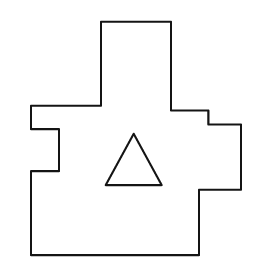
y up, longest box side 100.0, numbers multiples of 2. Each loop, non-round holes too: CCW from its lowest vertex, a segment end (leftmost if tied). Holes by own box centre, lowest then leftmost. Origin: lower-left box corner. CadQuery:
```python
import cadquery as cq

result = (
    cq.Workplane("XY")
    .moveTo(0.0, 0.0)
    .lineTo(72.0, 0.0)
    .lineTo(72.0, 28.0)
    .lineTo(90.0, 28.0)
    .lineTo(90.0, 56.0)
    .lineTo(76.0, 56.0)
    .lineTo(76.0, 62.0)
    .lineTo(60.0, 62.0)
    .lineTo(60.0, 100.0)
    .lineTo(30.0, 100.0)
    .lineTo(30.0, 64.0)
    .lineTo(0.0, 64.0)
    .lineTo(0.0, 54.0)
    .lineTo(12.0, 54.0)
    .lineTo(12.0, 36.0)
    .lineTo(0.0, 36.0)
    .close()
    .moveTo(32.0, 30.0)
    .lineTo(56.0, 30.0)
    .lineTo(44.0, 52.0)
    .close()
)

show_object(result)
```